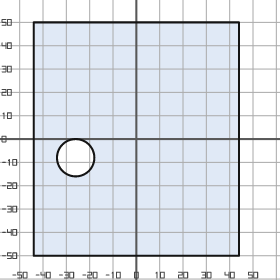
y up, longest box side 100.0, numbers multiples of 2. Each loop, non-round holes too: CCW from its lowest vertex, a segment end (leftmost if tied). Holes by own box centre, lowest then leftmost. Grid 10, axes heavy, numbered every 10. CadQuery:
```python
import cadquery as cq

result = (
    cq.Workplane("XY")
    .moveTo(-44.0, -50.0)
    .lineTo(44.0, -50.0)
    .lineTo(44.0, 50.0)
    .lineTo(-44.0, 50.0)
    .close()
    .moveTo(-26.0, -8.0)
    .circle(8.0)
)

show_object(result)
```